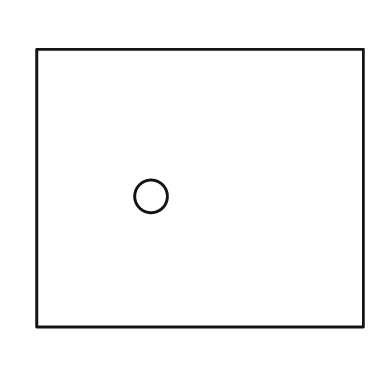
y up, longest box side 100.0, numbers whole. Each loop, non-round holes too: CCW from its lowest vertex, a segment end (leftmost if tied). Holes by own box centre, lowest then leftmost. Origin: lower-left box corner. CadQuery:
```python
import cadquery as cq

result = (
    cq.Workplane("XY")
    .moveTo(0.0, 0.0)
    .lineTo(100.0, 0.0)
    .lineTo(100.0, 85.0)
    .lineTo(0.0, 85.0)
    .close()
    .moveTo(35.0, 40.0)
    .circle(5.0)
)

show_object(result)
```